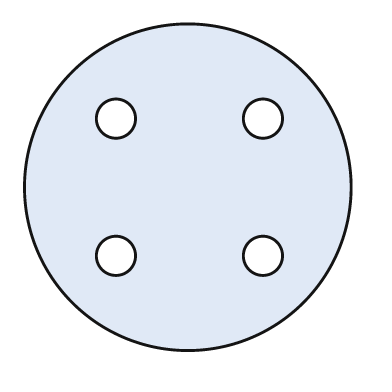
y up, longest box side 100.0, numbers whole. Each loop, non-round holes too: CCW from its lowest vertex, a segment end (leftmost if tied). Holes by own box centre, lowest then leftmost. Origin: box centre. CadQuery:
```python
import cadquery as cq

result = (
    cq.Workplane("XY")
    .moveTo(0.0, 0.0)
    .circle(50.0)
    .moveTo(-22.0, -21.0)
    .circle(6.0)
    .moveTo(23.0, -21.0)
    .circle(6.0)
    .moveTo(-22.0, 21.0)
    .circle(6.0)
    .moveTo(23.0, 21.0)
    .circle(6.0)
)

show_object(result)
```